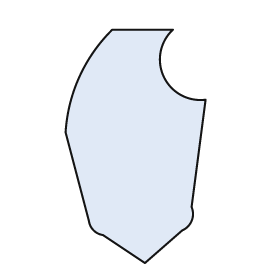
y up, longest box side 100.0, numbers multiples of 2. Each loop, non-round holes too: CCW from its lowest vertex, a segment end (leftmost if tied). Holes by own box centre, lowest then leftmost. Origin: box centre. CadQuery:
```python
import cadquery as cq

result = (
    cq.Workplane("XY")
    .moveTo(4.0, -50.0)
    .lineTo(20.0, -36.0)
    .threePointArc((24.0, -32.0), (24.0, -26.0))
    .lineTo(30.0, 20.0)
    .threePointArc((12.0, 30.0), (16.0, 50.0))
    .lineTo(-10.0, 50.0)
    .threePointArc((-24.0, 30.0), (-30.0, 6.0))
    .lineTo(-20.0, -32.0)
    .threePointArc((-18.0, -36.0), (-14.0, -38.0))
    .close()
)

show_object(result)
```